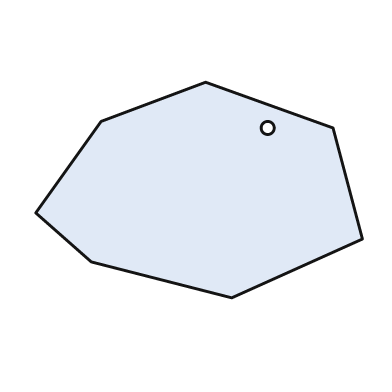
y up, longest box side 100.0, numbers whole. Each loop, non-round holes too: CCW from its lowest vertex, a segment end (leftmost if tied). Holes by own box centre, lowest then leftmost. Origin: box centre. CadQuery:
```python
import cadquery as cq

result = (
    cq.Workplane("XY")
    .moveTo(10.0, -33.0)
    .lineTo(50.0, -15.0)
    .lineTo(41.0, 19.0)
    .lineTo(2.0, 33.0)
    .lineTo(-30.0, 21.0)
    .lineTo(-50.0, -7.0)
    .lineTo(-33.0, -22.0)
    .close()
    .moveTo(21.0, 19.0)
    .circle(2.0)
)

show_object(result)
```